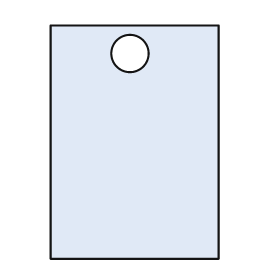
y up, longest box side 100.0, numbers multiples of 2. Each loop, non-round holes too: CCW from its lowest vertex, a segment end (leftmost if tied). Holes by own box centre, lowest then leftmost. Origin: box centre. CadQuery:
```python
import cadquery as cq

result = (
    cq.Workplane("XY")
    .moveTo(-36.0, -50.0)
    .lineTo(36.0, -50.0)
    .lineTo(36.0, 50.0)
    .lineTo(-36.0, 50.0)
    .close()
    .moveTo(-2.0, 38.0)
    .circle(8.0)
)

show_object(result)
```